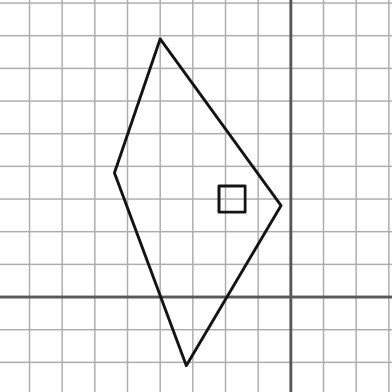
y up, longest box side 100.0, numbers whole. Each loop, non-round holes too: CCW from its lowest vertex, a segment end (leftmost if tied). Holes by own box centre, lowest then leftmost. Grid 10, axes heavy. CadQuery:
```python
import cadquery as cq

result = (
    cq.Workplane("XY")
    .moveTo(-32.0, -21.0)
    .lineTo(-3.0, 28.0)
    .lineTo(-40.0, 79.0)
    .lineTo(-54.0, 38.0)
    .close()
    .moveTo(-22.0, 26.0)
    .lineTo(-14.0, 26.0)
    .lineTo(-14.0, 34.0)
    .lineTo(-22.0, 34.0)
    .close()
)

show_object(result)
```